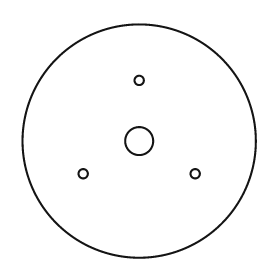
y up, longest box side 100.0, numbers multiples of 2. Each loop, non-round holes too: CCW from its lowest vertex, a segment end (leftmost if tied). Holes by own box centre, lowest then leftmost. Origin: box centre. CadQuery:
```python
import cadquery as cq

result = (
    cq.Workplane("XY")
    .moveTo(0.0, 0.0)
    .circle(50.0)
    .moveTo(-24.0, -14.0)
    .circle(2.0)
    .moveTo(24.0, -14.0)
    .circle(2.0)
    .moveTo(0.0, 0.0)
    .circle(6.0)
    .moveTo(0.0, 26.0)
    .circle(2.0)
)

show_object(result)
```